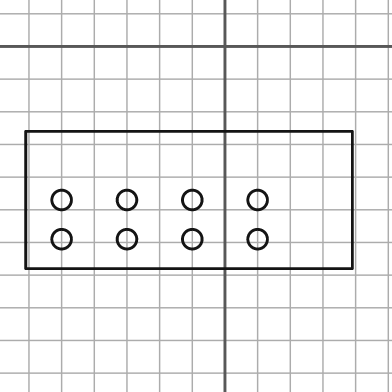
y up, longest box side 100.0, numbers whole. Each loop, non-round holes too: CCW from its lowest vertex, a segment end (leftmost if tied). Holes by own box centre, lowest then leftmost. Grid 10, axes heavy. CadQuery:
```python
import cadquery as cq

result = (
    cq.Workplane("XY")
    .moveTo(-61.0, -68.0)
    .lineTo(39.0, -68.0)
    .lineTo(39.0, -26.0)
    .lineTo(-61.0, -26.0)
    .close()
    .moveTo(-50.0, -59.0)
    .circle(3.0)
    .moveTo(-30.0, -59.0)
    .circle(3.0)
    .moveTo(-10.0, -59.0)
    .circle(3.0)
    .moveTo(10.0, -59.0)
    .circle(3.0)
    .moveTo(-50.0, -47.0)
    .circle(3.0)
    .moveTo(-30.0, -47.0)
    .circle(3.0)
    .moveTo(-10.0, -47.0)
    .circle(3.0)
    .moveTo(10.0, -47.0)
    .circle(3.0)
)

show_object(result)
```